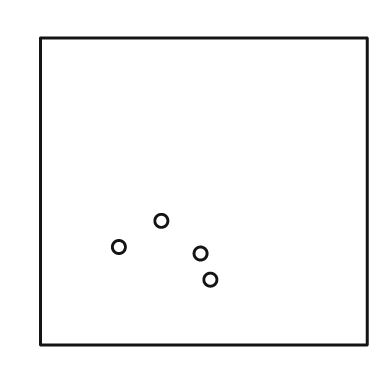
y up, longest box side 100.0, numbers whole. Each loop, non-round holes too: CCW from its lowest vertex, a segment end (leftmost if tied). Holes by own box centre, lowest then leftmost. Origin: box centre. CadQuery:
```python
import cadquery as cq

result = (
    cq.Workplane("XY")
    .moveTo(-50.0, -47.0)
    .lineTo(50.0, -47.0)
    .lineTo(50.0, 47.0)
    .lineTo(-50.0, 47.0)
    .close()
    .moveTo(2.0, -27.0)
    .circle(2.0)
    .moveTo(-1.0, -19.0)
    .circle(2.0)
    .moveTo(-26.0, -17.0)
    .circle(2.0)
    .moveTo(-13.0, -9.0)
    .circle(2.0)
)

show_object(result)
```